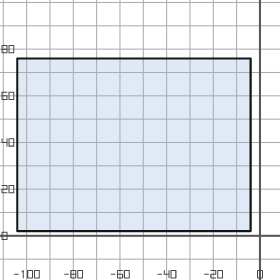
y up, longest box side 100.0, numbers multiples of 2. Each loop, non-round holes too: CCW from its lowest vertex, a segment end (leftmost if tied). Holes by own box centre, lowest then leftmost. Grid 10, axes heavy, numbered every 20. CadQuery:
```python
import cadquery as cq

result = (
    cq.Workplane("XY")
    .moveTo(-104.0, 2.0)
    .lineTo(-4.0, 2.0)
    .lineTo(-4.0, 76.0)
    .lineTo(-104.0, 76.0)
    .close()
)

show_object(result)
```